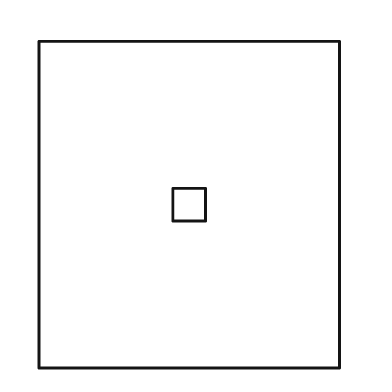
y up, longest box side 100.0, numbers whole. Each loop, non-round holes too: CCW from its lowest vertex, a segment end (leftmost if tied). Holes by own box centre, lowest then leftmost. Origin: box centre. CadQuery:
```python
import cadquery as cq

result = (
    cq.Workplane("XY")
    .moveTo(-46.0, -50.0)
    .lineTo(46.0, -50.0)
    .lineTo(46.0, 50.0)
    .lineTo(-46.0, 50.0)
    .close()
    .moveTo(-5.0, -5.0)
    .lineTo(5.0, -5.0)
    .lineTo(5.0, 5.0)
    .lineTo(-5.0, 5.0)
    .close()
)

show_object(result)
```